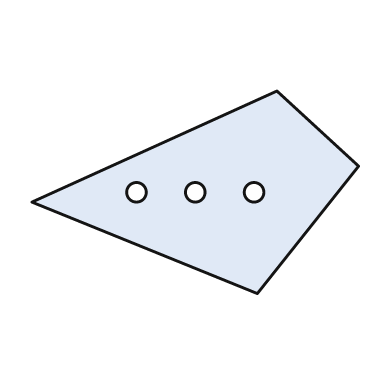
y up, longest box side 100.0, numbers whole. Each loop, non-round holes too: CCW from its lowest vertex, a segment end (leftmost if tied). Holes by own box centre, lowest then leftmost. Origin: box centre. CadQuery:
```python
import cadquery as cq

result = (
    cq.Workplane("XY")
    .moveTo(19.0, -31.0)
    .lineTo(50.0, 8.0)
    .lineTo(25.0, 31.0)
    .lineTo(-50.0, -3.0)
    .close()
    .moveTo(-18.0, 0.0)
    .circle(3.0)
    .moveTo(0.0, 0.0)
    .circle(3.0)
    .moveTo(18.0, 0.0)
    .circle(3.0)
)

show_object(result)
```